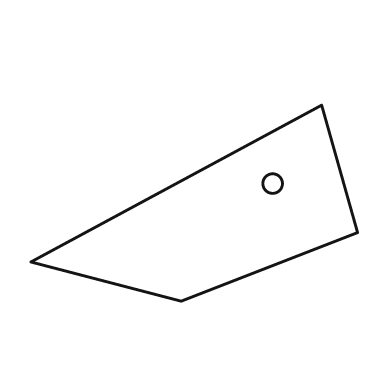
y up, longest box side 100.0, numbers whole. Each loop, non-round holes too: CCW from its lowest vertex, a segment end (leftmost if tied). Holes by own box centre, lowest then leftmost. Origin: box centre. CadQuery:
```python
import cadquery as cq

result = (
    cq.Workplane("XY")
    .moveTo(-4.0, -30.0)
    .lineTo(50.0, -9.0)
    .lineTo(39.0, 30.0)
    .lineTo(-50.0, -18.0)
    .close()
    .moveTo(24.0, 6.0)
    .circle(3.0)
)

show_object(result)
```